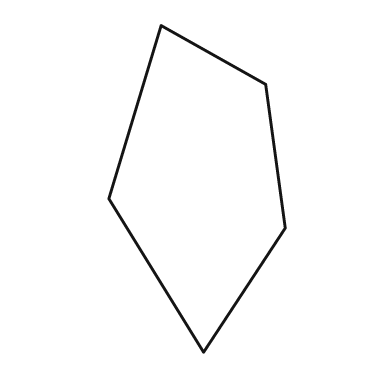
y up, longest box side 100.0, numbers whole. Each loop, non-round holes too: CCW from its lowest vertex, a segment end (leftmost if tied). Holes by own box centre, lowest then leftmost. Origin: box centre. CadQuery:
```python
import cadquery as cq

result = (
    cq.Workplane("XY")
    .moveTo(2.0, -50.0)
    .lineTo(27.0, -12.0)
    .lineTo(21.0, 32.0)
    .lineTo(-11.0, 50.0)
    .lineTo(-27.0, -3.0)
    .close()
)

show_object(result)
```